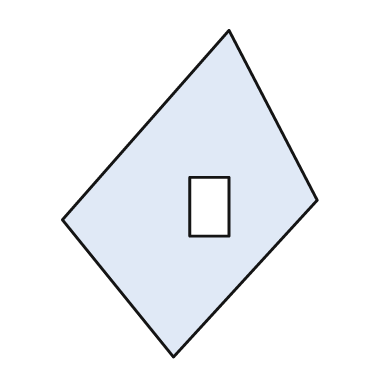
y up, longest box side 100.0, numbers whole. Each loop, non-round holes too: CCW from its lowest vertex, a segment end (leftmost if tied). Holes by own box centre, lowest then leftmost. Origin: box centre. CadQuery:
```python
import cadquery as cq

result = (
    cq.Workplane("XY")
    .moveTo(-5.0, -50.0)
    .lineTo(39.0, -2.0)
    .lineTo(12.0, 50.0)
    .lineTo(-39.0, -8.0)
    .close()
    .moveTo(0.0, -13.0)
    .lineTo(12.0, -13.0)
    .lineTo(12.0, 5.0)
    .lineTo(0.0, 5.0)
    .close()
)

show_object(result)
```